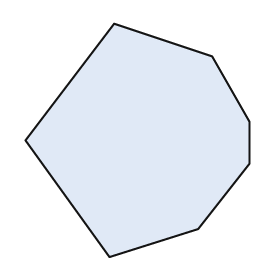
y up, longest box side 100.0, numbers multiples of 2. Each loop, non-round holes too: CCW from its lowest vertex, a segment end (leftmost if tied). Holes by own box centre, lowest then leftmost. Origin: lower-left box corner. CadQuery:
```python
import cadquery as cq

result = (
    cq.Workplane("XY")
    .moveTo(36.0, 0.0)
    .lineTo(74.0, 12.0)
    .lineTo(96.0, 40.0)
    .lineTo(96.0, 58.0)
    .lineTo(80.0, 86.0)
    .lineTo(38.0, 100.0)
    .lineTo(0.0, 50.0)
    .close()
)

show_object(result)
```